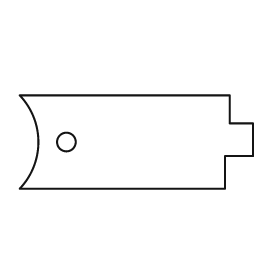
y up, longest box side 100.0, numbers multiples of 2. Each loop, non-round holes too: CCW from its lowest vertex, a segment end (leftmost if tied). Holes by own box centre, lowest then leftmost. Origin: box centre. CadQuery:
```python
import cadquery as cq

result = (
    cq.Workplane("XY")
    .moveTo(-50.0, -20.0)
    .lineTo(38.0, -20.0)
    .lineTo(38.0, -6.0)
    .lineTo(50.0, -6.0)
    .lineTo(50.0, 8.0)
    .lineTo(40.0, 8.0)
    .lineTo(40.0, 20.0)
    .lineTo(-50.0, 20.0)
    .threePointArc((-42.0, 0.0), (-50.0, -20.0))
    .close()
    .moveTo(-30.0, 0.0)
    .circle(4.0)
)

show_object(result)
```